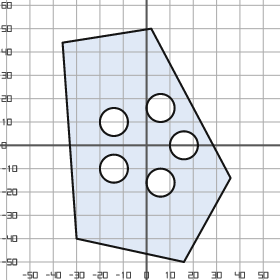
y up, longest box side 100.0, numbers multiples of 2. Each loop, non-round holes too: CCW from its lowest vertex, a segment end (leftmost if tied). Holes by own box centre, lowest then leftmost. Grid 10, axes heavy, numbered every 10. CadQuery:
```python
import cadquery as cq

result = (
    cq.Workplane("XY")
    .moveTo(16.0, -50.0)
    .lineTo(36.0, -14.0)
    .lineTo(2.0, 50.0)
    .lineTo(-36.0, 44.0)
    .lineTo(-30.0, -40.0)
    .close()
    .moveTo(6.0, -16.0)
    .circle(6.0)
    .moveTo(-14.0, -10.0)
    .circle(6.0)
    .moveTo(16.0, 0.0)
    .circle(6.0)
    .moveTo(-14.0, 10.0)
    .circle(6.0)
    .moveTo(6.0, 16.0)
    .circle(6.0)
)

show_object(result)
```